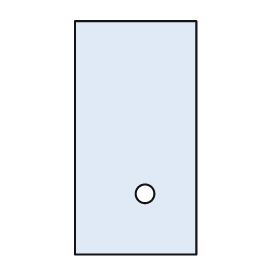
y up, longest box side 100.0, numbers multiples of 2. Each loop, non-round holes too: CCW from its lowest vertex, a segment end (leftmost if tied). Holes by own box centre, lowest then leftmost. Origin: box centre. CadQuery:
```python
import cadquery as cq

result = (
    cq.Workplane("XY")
    .moveTo(-26.0, -50.0)
    .lineTo(26.0, -50.0)
    .lineTo(26.0, 50.0)
    .lineTo(-26.0, 50.0)
    .close()
    .moveTo(4.0, -24.0)
    .circle(4.0)
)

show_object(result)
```